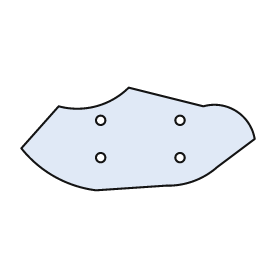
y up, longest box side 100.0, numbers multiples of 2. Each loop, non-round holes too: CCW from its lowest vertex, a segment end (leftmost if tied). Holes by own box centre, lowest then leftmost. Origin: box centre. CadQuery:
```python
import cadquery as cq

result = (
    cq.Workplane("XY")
    .moveTo(-18.0, -22.0)
    .lineTo(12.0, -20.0)
    .threePointArc((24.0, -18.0), (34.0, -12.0))
    .lineTo(50.0, 0.0)
    .threePointArc((42.0, 12.0), (28.0, 14.0))
    .lineTo(-4.0, 22.0)
    .threePointArc((-18.0, 14.0), (-34.0, 14.0))
    .lineTo(-50.0, -4.0)
    .threePointArc((-36.0, -16.0), (-18.0, -22.0))
    .close()
    .moveTo(-16.0, -8.0)
    .circle(2.0)
    .moveTo(18.0, -8.0)
    .circle(2.0)
    .moveTo(-16.0, 8.0)
    .circle(2.0)
    .moveTo(18.0, 8.0)
    .circle(2.0)
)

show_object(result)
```